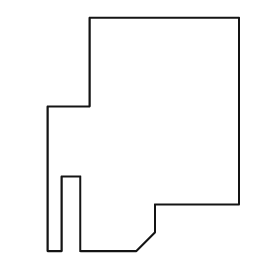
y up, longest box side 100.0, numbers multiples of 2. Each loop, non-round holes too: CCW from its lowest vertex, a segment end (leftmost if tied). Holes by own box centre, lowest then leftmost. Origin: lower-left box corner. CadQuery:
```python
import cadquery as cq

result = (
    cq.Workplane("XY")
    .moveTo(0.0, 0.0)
    .lineTo(6.0, 0.0)
    .lineTo(6.0, 32.0)
    .lineTo(14.0, 32.0)
    .lineTo(14.0, 0.0)
    .lineTo(38.0, 0.0)
    .lineTo(46.0, 8.0)
    .lineTo(46.0, 20.0)
    .lineTo(82.0, 20.0)
    .lineTo(82.0, 100.0)
    .lineTo(18.0, 100.0)
    .lineTo(18.0, 62.0)
    .lineTo(0.0, 62.0)
    .close()
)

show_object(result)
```